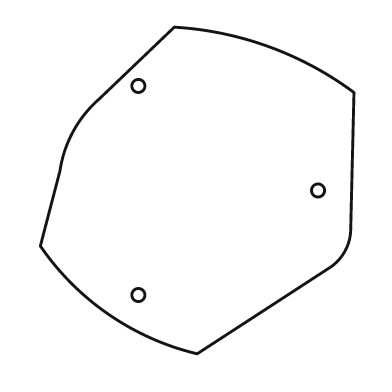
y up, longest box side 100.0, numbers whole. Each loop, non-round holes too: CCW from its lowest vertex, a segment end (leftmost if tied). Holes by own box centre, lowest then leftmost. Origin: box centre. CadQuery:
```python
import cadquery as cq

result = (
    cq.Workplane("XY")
    .moveTo(0.0, -50.0)
    .lineTo(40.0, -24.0)
    .threePointArc((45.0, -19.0), (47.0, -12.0))
    .lineTo(48.0, 30.0)
    .threePointArc((22.0, 44.0), (-7.0, 50.0))
    .lineTo(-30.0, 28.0)
    .threePointArc((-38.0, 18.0), (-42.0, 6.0))
    .lineTo(-48.0, -17.0)
    .threePointArc((-27.0, -38.0), (0.0, -50.0))
    .close()
    .moveTo(-18.0, -32.0)
    .circle(2.0)
    .moveTo(37.0, 0.0)
    .circle(2.0)
    .moveTo(-18.0, 32.0)
    .circle(2.0)
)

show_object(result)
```